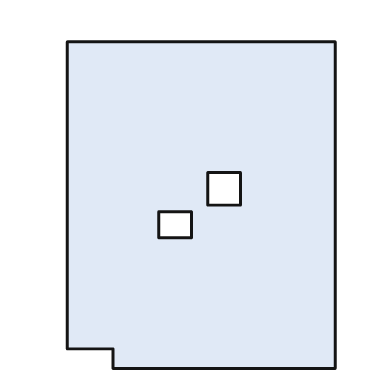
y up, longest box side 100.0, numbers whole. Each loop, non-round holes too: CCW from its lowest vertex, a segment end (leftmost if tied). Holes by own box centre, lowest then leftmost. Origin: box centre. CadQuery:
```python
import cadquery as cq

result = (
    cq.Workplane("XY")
    .moveTo(-27.0, -50.0)
    .lineTo(41.0, -50.0)
    .lineTo(41.0, 50.0)
    .lineTo(-41.0, 50.0)
    .lineTo(-41.0, -44.0)
    .lineTo(-27.0, -44.0)
    .close()
    .moveTo(-13.0, -10.0)
    .lineTo(-3.0, -10.0)
    .lineTo(-3.0, -2.0)
    .lineTo(-13.0, -2.0)
    .close()
    .moveTo(2.0, 0.0)
    .lineTo(12.0, 0.0)
    .lineTo(12.0, 10.0)
    .lineTo(2.0, 10.0)
    .close()
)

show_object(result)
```